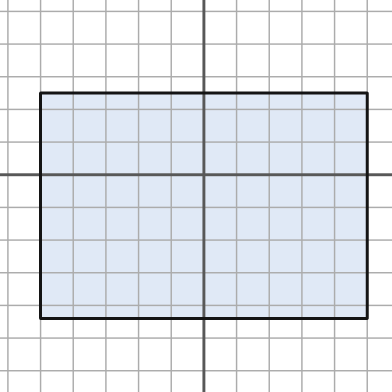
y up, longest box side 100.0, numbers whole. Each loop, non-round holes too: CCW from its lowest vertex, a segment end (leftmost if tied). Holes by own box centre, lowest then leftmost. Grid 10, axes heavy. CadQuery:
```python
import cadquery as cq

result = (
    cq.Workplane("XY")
    .moveTo(-50.0, -44.0)
    .lineTo(50.0, -44.0)
    .lineTo(50.0, 25.0)
    .lineTo(-50.0, 25.0)
    .close()
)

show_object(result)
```